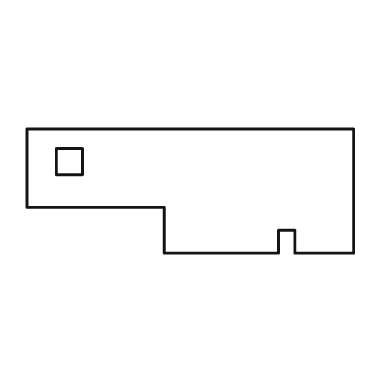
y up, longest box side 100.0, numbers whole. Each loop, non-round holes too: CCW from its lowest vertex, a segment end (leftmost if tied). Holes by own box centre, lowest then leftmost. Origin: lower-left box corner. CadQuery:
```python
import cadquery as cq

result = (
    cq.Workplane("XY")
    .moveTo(42.0, 0.0)
    .lineTo(77.0, 0.0)
    .lineTo(77.0, 7.0)
    .lineTo(82.0, 7.0)
    .lineTo(82.0, 0.0)
    .lineTo(100.0, 0.0)
    .lineTo(100.0, 38.0)
    .lineTo(0.0, 38.0)
    .lineTo(0.0, 14.0)
    .lineTo(42.0, 14.0)
    .close()
    .moveTo(9.0, 24.0)
    .lineTo(17.0, 24.0)
    .lineTo(17.0, 32.0)
    .lineTo(9.0, 32.0)
    .close()
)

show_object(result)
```